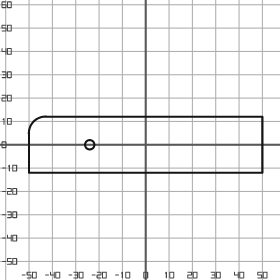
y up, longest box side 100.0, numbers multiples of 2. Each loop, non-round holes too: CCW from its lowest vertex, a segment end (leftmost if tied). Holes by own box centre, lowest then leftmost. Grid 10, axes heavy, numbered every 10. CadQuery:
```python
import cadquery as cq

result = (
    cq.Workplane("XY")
    .moveTo(-50.0, -12.0)
    .lineTo(50.0, -12.0)
    .lineTo(50.0, 12.0)
    .lineTo(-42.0, 12.0)
    .threePointArc((-48.0, 10.0), (-50.0, 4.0))
    .close()
    .moveTo(-24.0, 0.0)
    .circle(2.0)
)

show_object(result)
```